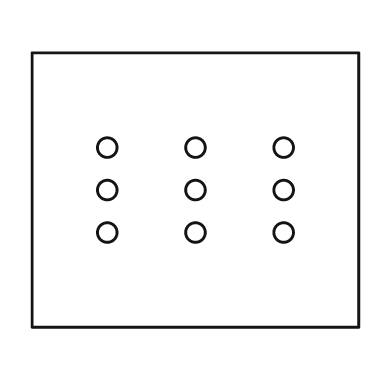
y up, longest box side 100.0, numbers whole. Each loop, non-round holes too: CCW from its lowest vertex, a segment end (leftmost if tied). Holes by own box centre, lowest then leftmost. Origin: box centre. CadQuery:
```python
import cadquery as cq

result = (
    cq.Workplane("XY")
    .moveTo(-50.0, -42.0)
    .lineTo(50.0, -42.0)
    .lineTo(50.0, 42.0)
    .lineTo(-50.0, 42.0)
    .close()
    .moveTo(-27.0, -13.0)
    .circle(3.0)
    .moveTo(0.0, -13.0)
    .circle(3.0)
    .moveTo(27.0, -13.0)
    .circle(3.0)
    .moveTo(-27.0, 0.0)
    .circle(3.0)
    .moveTo(0.0, 0.0)
    .circle(3.0)
    .moveTo(27.0, 0.0)
    .circle(3.0)
    .moveTo(-27.0, 13.0)
    .circle(3.0)
    .moveTo(0.0, 13.0)
    .circle(3.0)
    .moveTo(27.0, 13.0)
    .circle(3.0)
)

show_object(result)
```